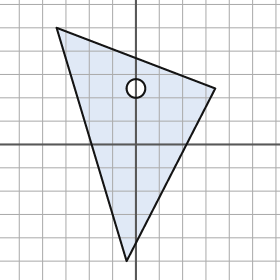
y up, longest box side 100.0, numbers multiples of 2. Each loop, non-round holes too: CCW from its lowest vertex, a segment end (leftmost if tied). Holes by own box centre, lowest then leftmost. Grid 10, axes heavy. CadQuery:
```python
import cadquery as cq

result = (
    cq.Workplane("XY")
    .moveTo(-4.0, -50.0)
    .lineTo(34.0, 24.0)
    .lineTo(-34.0, 50.0)
    .close()
    .moveTo(0.0, 24.0)
    .circle(4.0)
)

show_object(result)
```